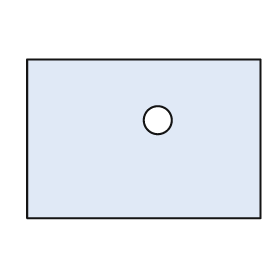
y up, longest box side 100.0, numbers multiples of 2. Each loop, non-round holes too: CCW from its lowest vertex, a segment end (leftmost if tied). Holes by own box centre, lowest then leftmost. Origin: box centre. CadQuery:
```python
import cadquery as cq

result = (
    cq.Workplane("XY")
    .moveTo(-50.0, -34.0)
    .lineTo(50.0, -34.0)
    .lineTo(50.0, 34.0)
    .lineTo(-50.0, 34.0)
    .close()
    .moveTo(6.0, 8.0)
    .circle(6.0)
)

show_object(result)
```